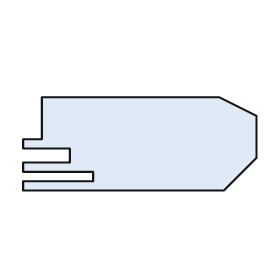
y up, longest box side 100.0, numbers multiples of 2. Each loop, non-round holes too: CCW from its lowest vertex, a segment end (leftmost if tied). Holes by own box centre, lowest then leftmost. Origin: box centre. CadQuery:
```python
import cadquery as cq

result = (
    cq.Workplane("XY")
    .moveTo(-50.0, -20.0)
    .lineTo(36.0, -20.0)
    .lineTo(50.0, -6.0)
    .lineTo(50.0, 12.0)
    .lineTo(34.0, 20.0)
    .lineTo(-42.0, 20.0)
    .lineTo(-42.0, 2.0)
    .lineTo(-50.0, 2.0)
    .lineTo(-50.0, -2.0)
    .lineTo(-30.0, -2.0)
    .lineTo(-30.0, -8.0)
    .lineTo(-50.0, -8.0)
    .lineTo(-50.0, -12.0)
    .lineTo(-20.0, -12.0)
    .lineTo(-20.0, -16.0)
    .lineTo(-50.0, -16.0)
    .close()
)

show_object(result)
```